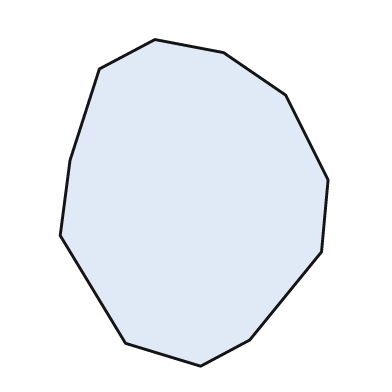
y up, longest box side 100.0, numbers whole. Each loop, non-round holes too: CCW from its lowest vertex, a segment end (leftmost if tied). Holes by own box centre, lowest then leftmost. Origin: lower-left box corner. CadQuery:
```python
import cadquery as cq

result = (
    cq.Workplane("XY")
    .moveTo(43.0, 0.0)
    .lineTo(58.0, 8.0)
    .lineTo(80.0, 35.0)
    .lineTo(82.0, 57.0)
    .lineTo(69.0, 83.0)
    .lineTo(50.0, 96.0)
    .lineTo(29.0, 100.0)
    .lineTo(12.0, 91.0)
    .lineTo(3.0, 63.0)
    .lineTo(0.0, 40.0)
    .lineTo(20.0, 7.0)
    .close()
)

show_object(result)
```